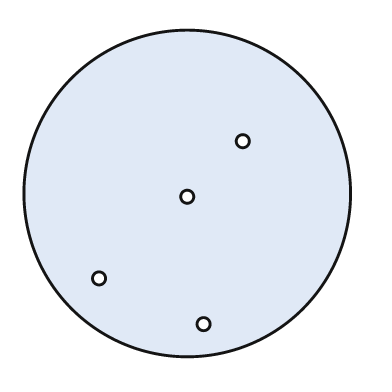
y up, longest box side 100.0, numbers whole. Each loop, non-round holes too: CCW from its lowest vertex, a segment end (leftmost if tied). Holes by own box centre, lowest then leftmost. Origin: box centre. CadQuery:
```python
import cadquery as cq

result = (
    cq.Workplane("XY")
    .moveTo(0.0, 0.0)
    .circle(50.0)
    .moveTo(5.0, -40.0)
    .circle(2.0)
    .moveTo(-27.0, -26.0)
    .circle(2.0)
    .moveTo(0.0, -1.0)
    .circle(2.0)
    .moveTo(17.0, 16.0)
    .circle(2.0)
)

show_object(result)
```